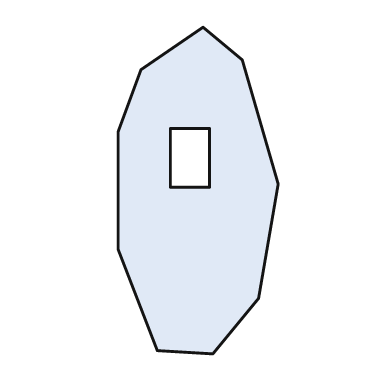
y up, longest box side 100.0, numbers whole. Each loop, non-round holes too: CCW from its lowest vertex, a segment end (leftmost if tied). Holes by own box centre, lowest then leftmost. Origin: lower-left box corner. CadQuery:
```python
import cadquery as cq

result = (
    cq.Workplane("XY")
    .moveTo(29.0, 0.0)
    .lineTo(43.0, 17.0)
    .lineTo(49.0, 52.0)
    .lineTo(38.0, 90.0)
    .lineTo(26.0, 100.0)
    .lineTo(7.0, 87.0)
    .lineTo(0.0, 68.0)
    .lineTo(0.0, 32.0)
    .lineTo(12.0, 1.0)
    .close()
    .moveTo(16.0, 51.0)
    .lineTo(28.0, 51.0)
    .lineTo(28.0, 69.0)
    .lineTo(16.0, 69.0)
    .close()
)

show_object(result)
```